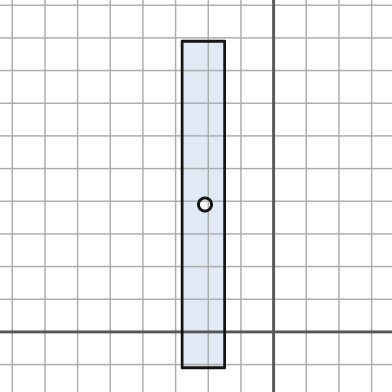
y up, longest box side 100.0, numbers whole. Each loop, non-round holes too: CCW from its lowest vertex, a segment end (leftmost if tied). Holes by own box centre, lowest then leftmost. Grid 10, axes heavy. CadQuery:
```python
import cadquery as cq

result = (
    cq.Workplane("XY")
    .moveTo(-28.0, -11.0)
    .lineTo(-15.0, -11.0)
    .lineTo(-15.0, 89.0)
    .lineTo(-28.0, 89.0)
    .close()
    .moveTo(-21.0, 39.0)
    .circle(2.0)
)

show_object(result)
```